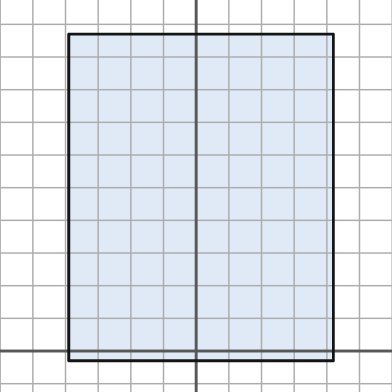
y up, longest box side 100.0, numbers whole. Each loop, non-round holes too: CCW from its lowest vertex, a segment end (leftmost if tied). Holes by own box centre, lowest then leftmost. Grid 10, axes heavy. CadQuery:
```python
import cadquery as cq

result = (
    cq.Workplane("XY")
    .moveTo(-39.0, -3.0)
    .lineTo(42.0, -3.0)
    .lineTo(42.0, 97.0)
    .lineTo(-39.0, 97.0)
    .close()
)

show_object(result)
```